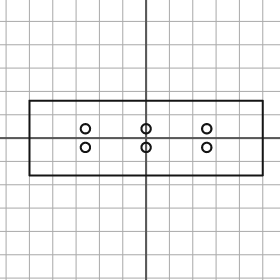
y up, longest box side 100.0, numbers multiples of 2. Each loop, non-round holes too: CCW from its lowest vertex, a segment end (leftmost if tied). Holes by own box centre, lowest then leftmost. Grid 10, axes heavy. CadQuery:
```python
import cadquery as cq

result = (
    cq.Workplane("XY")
    .moveTo(-50.0, -16.0)
    .lineTo(50.0, -16.0)
    .lineTo(50.0, 16.0)
    .lineTo(-50.0, 16.0)
    .close()
    .moveTo(-26.0, -4.0)
    .circle(2.0)
    .moveTo(0.0, -4.0)
    .circle(2.0)
    .moveTo(26.0, -4.0)
    .circle(2.0)
    .moveTo(-26.0, 4.0)
    .circle(2.0)
    .moveTo(0.0, 4.0)
    .circle(2.0)
    .moveTo(26.0, 4.0)
    .circle(2.0)
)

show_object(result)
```